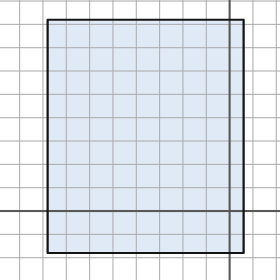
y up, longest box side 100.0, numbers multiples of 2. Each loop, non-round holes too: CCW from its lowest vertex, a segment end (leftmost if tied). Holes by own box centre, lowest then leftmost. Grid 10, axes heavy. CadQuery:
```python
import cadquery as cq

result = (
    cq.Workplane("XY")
    .moveTo(-78.0, -18.0)
    .lineTo(6.0, -18.0)
    .lineTo(6.0, 82.0)
    .lineTo(-78.0, 82.0)
    .close()
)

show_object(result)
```